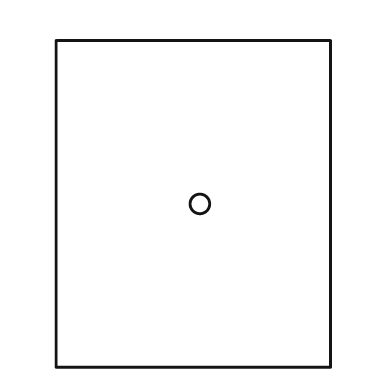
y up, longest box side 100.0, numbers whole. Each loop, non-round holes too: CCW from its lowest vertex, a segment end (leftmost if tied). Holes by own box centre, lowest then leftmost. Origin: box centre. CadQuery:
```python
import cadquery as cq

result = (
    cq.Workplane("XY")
    .moveTo(-42.0, -50.0)
    .lineTo(42.0, -50.0)
    .lineTo(42.0, 50.0)
    .lineTo(-42.0, 50.0)
    .close()
    .moveTo(2.0, 0.0)
    .circle(3.0)
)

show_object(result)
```